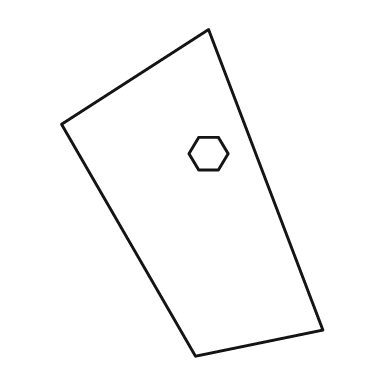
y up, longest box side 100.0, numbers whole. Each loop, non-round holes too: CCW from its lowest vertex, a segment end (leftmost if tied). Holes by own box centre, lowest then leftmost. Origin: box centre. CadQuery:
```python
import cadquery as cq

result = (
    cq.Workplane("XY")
    .moveTo(1.0, -50.0)
    .lineTo(40.0, -42.0)
    .lineTo(5.0, 50.0)
    .lineTo(-40.0, 21.0)
    .close()
    .moveTo(2.0, 7.0)
    .lineTo(8.0, 7.0)
    .lineTo(11.0, 12.0)
    .lineTo(8.0, 17.0)
    .lineTo(2.0, 17.0)
    .lineTo(-1.0, 12.0)
    .close()
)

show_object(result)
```